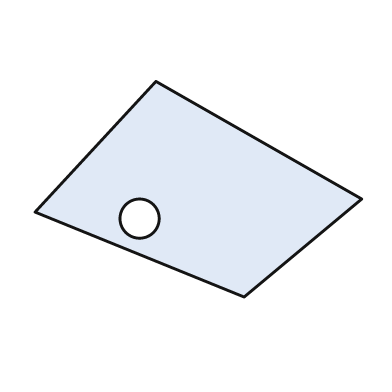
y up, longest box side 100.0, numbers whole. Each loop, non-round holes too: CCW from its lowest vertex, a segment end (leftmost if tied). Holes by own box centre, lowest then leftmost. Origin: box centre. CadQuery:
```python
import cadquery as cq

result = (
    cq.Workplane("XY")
    .moveTo(14.0, -33.0)
    .lineTo(50.0, -3.0)
    .lineTo(-13.0, 33.0)
    .lineTo(-50.0, -7.0)
    .close()
    .moveTo(-18.0, -9.0)
    .circle(6.0)
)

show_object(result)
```